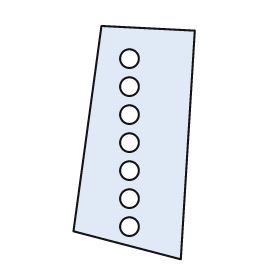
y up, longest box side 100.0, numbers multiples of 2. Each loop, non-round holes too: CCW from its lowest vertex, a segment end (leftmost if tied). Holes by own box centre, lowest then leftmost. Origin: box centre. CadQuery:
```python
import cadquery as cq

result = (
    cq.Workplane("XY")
    .moveTo(20.0, -50.0)
    .lineTo(26.0, 48.0)
    .lineTo(-14.0, 50.0)
    .lineTo(-26.0, -38.0)
    .close()
    .moveTo(-2.0, -36.0)
    .circle(4.0)
    .moveTo(-2.0, -24.0)
    .circle(4.0)
    .moveTo(-2.0, -12.0)
    .circle(4.0)
    .moveTo(-2.0, 0.0)
    .circle(4.0)
    .moveTo(-2.0, 12.0)
    .circle(4.0)
    .moveTo(-2.0, 24.0)
    .circle(4.0)
    .moveTo(-2.0, 36.0)
    .circle(4.0)
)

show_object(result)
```